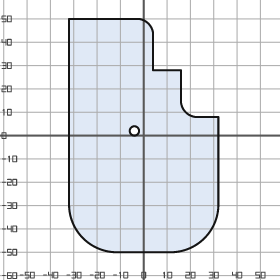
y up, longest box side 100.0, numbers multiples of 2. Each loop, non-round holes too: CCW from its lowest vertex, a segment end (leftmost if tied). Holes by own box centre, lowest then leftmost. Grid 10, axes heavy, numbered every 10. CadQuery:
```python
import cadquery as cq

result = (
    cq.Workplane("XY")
    .moveTo(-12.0, -50.0)
    .lineTo(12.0, -50.0)
    .threePointArc((26.0, -44.0), (32.0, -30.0))
    .lineTo(32.0, 8.0)
    .lineTo(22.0, 8.0)
    .threePointArc((18.0, 10.0), (16.0, 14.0))
    .lineTo(16.0, 28.0)
    .lineTo(4.0, 28.0)
    .lineTo(4.0, 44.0)
    .threePointArc((2.0, 48.0), (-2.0, 50.0))
    .lineTo(-32.0, 50.0)
    .lineTo(-32.0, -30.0)
    .threePointArc((-26.0, -44.0), (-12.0, -50.0))
    .close()
    .moveTo(-4.0, 2.0)
    .circle(2.0)
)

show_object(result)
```